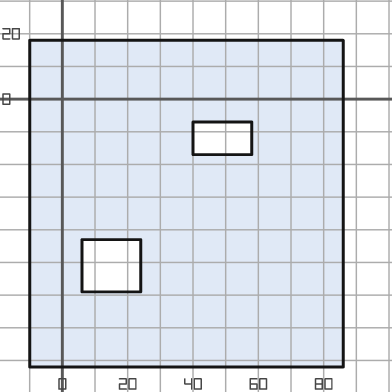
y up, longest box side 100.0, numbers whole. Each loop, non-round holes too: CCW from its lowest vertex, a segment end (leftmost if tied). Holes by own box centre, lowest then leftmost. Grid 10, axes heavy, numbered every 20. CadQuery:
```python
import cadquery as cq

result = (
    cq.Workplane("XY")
    .moveTo(-10.0, -82.0)
    .lineTo(86.0, -82.0)
    .lineTo(86.0, 18.0)
    .lineTo(-10.0, 18.0)
    .close()
    .moveTo(6.0, -59.0)
    .lineTo(24.0, -59.0)
    .lineTo(24.0, -43.0)
    .lineTo(6.0, -43.0)
    .close()
    .moveTo(40.0, -17.0)
    .lineTo(58.0, -17.0)
    .lineTo(58.0, -7.0)
    .lineTo(40.0, -7.0)
    .close()
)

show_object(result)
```